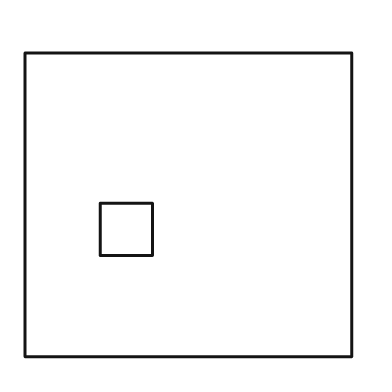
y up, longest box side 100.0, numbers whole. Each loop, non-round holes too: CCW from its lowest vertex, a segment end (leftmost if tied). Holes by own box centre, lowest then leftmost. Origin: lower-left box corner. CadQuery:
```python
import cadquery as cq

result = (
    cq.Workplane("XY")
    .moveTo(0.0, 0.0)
    .lineTo(100.0, 0.0)
    .lineTo(100.0, 93.0)
    .lineTo(0.0, 93.0)
    .close()
    .moveTo(23.0, 31.0)
    .lineTo(39.0, 31.0)
    .lineTo(39.0, 47.0)
    .lineTo(23.0, 47.0)
    .close()
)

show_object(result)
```